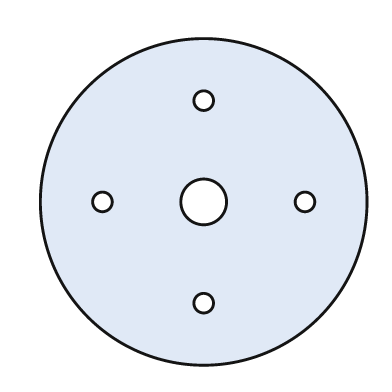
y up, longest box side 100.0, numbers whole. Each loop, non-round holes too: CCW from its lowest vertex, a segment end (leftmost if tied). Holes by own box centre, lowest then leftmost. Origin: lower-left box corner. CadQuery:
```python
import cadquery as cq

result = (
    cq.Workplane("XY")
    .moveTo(50.0, 50.0)
    .circle(50.0)
    .moveTo(50.0, 19.0)
    .circle(3.0)
    .moveTo(19.0, 50.0)
    .circle(3.0)
    .moveTo(50.0, 50.0)
    .circle(7.0)
    .moveTo(81.0, 50.0)
    .circle(3.0)
    .moveTo(50.0, 81.0)
    .circle(3.0)
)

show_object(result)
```